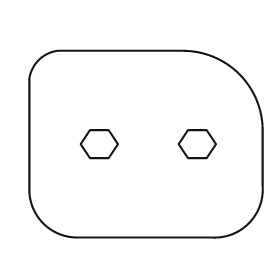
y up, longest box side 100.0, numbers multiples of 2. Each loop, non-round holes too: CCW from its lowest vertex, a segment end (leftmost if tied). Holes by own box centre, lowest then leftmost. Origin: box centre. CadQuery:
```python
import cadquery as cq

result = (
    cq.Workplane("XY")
    .moveTo(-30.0, -40.0)
    .lineTo(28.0, -40.0)
    .threePointArc((44.0, -34.0), (50.0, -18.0))
    .lineTo(50.0, 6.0)
    .threePointArc((40.0, 30.0), (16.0, 40.0))
    .lineTo(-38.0, 40.0)
    .threePointArc((-46.0, 36.0), (-50.0, 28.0))
    .lineTo(-50.0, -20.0)
    .threePointArc((-44.0, -34.0), (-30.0, -40.0))
    .close()
    .moveTo(-24.0, -6.0)
    .lineTo(-16.0, -6.0)
    .lineTo(-12.0, 0.0)
    .lineTo(-16.0, 6.0)
    .lineTo(-24.0, 6.0)
    .lineTo(-28.0, 0.0)
    .close()
    .moveTo(18.0, -6.0)
    .lineTo(26.0, -6.0)
    .lineTo(30.0, 0.0)
    .lineTo(26.0, 6.0)
    .lineTo(18.0, 6.0)
    .lineTo(14.0, 0.0)
    .close()
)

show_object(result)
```